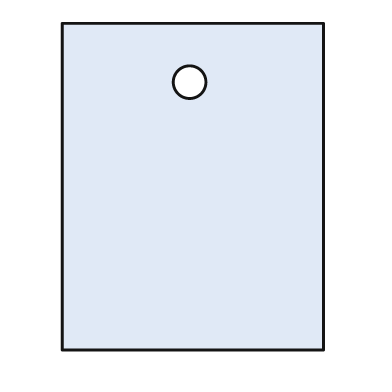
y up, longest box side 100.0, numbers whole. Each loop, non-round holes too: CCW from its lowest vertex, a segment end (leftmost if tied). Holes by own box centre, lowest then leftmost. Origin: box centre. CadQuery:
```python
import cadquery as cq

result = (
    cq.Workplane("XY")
    .moveTo(-40.0, -50.0)
    .lineTo(40.0, -50.0)
    .lineTo(40.0, 50.0)
    .lineTo(-40.0, 50.0)
    .close()
    .moveTo(-1.0, 32.0)
    .circle(5.0)
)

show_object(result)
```